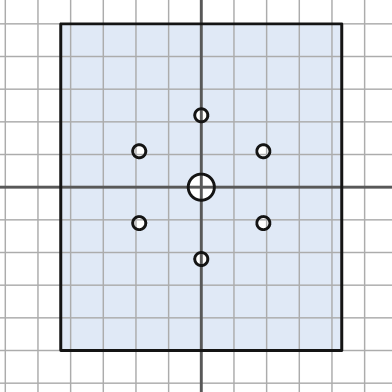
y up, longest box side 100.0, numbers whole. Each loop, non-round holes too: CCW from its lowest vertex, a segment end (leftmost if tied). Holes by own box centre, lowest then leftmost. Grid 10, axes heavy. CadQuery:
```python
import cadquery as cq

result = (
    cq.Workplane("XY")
    .moveTo(-43.0, -50.0)
    .lineTo(43.0, -50.0)
    .lineTo(43.0, 50.0)
    .lineTo(-43.0, 50.0)
    .close()
    .moveTo(0.0, -22.0)
    .circle(2.0)
    .moveTo(-19.0, -11.0)
    .circle(2.0)
    .moveTo(19.0, -11.0)
    .circle(2.0)
    .moveTo(0.0, 0.0)
    .circle(4.0)
    .moveTo(-19.0, 11.0)
    .circle(2.0)
    .moveTo(19.0, 11.0)
    .circle(2.0)
    .moveTo(0.0, 22.0)
    .circle(2.0)
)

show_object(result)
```